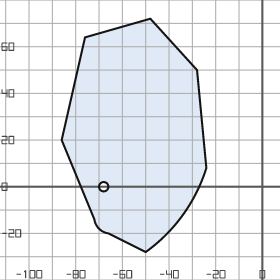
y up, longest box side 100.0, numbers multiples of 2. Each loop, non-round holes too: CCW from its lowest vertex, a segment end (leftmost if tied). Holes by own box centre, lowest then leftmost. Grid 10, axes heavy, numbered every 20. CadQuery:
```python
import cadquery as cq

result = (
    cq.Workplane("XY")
    .moveTo(-50.0, -28.0)
    .threePointArc((-34.0, -12.0), (-24.0, 8.0))
    .lineTo(-28.0, 50.0)
    .lineTo(-48.0, 72.0)
    .lineTo(-76.0, 64.0)
    .lineTo(-86.0, 20.0)
    .lineTo(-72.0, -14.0)
    .threePointArc((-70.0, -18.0), (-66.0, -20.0))
    .close()
    .moveTo(-68.0, 0.0)
    .circle(2.0)
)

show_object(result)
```